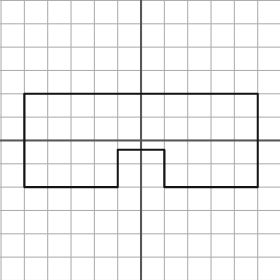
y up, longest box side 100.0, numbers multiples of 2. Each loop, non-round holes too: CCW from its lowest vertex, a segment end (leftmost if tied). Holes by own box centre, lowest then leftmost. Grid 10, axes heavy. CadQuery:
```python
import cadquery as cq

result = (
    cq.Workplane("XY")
    .moveTo(-50.0, -20.0)
    .lineTo(-10.0, -20.0)
    .lineTo(-10.0, -4.0)
    .lineTo(10.0, -4.0)
    .lineTo(10.0, -20.0)
    .lineTo(50.0, -20.0)
    .lineTo(50.0, 20.0)
    .lineTo(-50.0, 20.0)
    .close()
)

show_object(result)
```